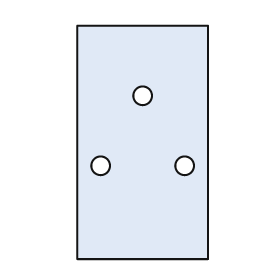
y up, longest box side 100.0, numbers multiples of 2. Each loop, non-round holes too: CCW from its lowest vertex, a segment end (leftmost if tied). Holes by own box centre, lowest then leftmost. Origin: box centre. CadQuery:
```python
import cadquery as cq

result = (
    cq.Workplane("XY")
    .moveTo(-28.0, -50.0)
    .lineTo(28.0, -50.0)
    .lineTo(28.0, 50.0)
    .lineTo(-28.0, 50.0)
    .close()
    .moveTo(-18.0, -10.0)
    .circle(4.0)
    .moveTo(18.0, -10.0)
    .circle(4.0)
    .moveTo(0.0, 20.0)
    .circle(4.0)
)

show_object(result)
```